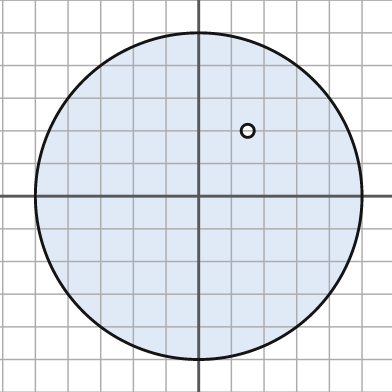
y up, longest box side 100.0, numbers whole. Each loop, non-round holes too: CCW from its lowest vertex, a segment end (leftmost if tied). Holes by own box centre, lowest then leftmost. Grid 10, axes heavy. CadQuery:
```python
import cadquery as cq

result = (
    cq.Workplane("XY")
    .moveTo(0.0, 0.0)
    .circle(50.0)
    .moveTo(15.0, 20.0)
    .circle(2.0)
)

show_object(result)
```